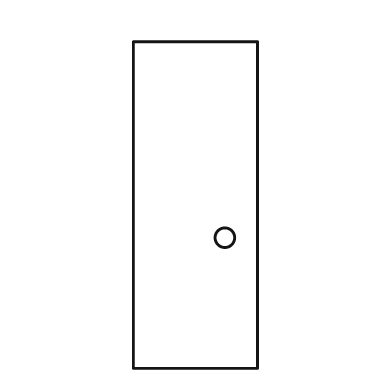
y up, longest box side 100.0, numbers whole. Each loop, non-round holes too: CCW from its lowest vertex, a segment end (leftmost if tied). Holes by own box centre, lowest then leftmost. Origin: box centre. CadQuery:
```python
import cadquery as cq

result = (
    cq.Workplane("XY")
    .moveTo(-19.0, -50.0)
    .lineTo(19.0, -50.0)
    .lineTo(19.0, 50.0)
    .lineTo(-19.0, 50.0)
    .close()
    .moveTo(9.0, -10.0)
    .circle(3.0)
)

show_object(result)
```